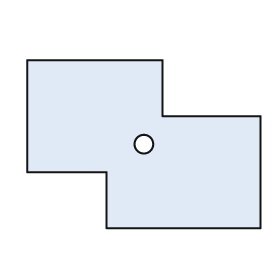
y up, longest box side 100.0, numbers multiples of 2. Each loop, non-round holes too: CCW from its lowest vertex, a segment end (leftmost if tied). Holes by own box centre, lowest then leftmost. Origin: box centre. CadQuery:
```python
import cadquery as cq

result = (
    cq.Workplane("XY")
    .moveTo(-16.0, -36.0)
    .lineTo(50.0, -36.0)
    .lineTo(50.0, 12.0)
    .lineTo(8.0, 12.0)
    .lineTo(8.0, 36.0)
    .lineTo(-50.0, 36.0)
    .lineTo(-50.0, -12.0)
    .lineTo(-16.0, -12.0)
    .close()
    .moveTo(0.0, 0.0)
    .circle(4.0)
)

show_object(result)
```